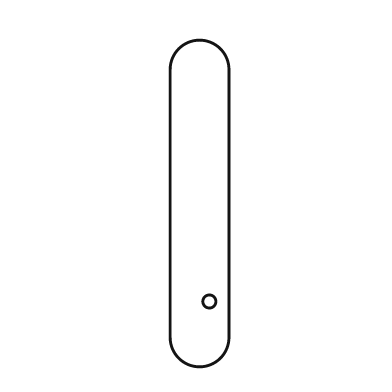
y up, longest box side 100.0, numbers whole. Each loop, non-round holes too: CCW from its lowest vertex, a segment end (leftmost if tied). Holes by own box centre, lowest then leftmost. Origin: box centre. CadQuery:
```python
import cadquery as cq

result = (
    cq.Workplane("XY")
    .moveTo(-9.0, -41.0)
    .threePointArc((0.0, -50.0), (9.0, -41.0))
    .lineTo(9.0, 41.0)
    .threePointArc((0.0, 50.0), (-9.0, 41.0))
    .close()
    .moveTo(3.0, -30.0)
    .circle(2.0)
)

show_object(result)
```